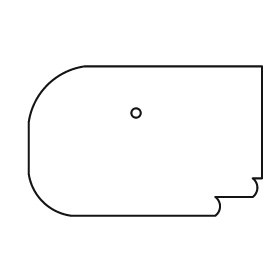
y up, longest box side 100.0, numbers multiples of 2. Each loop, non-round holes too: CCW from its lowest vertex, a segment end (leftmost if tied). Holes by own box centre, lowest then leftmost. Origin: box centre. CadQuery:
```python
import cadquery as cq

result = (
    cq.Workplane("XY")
    .moveTo(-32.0, -32.0)
    .lineTo(30.0, -32.0)
    .threePointArc((32.0, -28.0), (30.0, -24.0))
    .lineTo(46.0, -24.0)
    .threePointArc((48.0, -20.0), (46.0, -16.0))
    .lineTo(50.0, -16.0)
    .lineTo(50.0, 32.0)
    .lineTo(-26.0, 32.0)
    .threePointArc((-42.0, 24.0), (-50.0, 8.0))
    .lineTo(-50.0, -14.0)
    .threePointArc((-44.0, -26.0), (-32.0, -32.0))
    .close()
    .moveTo(-4.0, 12.0)
    .circle(2.0)
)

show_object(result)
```